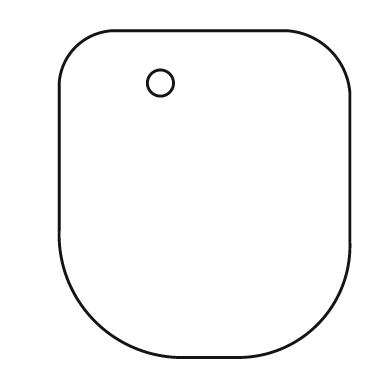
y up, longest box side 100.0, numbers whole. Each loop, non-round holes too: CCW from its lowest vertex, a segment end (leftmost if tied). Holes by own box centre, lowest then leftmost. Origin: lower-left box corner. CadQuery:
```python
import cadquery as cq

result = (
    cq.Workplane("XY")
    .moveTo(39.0, 0.0)
    .lineTo(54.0, 0.0)
    .threePointArc((79.0, 10.0), (89.0, 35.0))
    .lineTo(89.0, 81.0)
    .threePointArc((83.0, 94.0), (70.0, 100.0))
    .lineTo(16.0, 100.0)
    .threePointArc((5.0, 95.0), (0.0, 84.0))
    .lineTo(0.0, 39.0)
    .threePointArc((11.0, 11.0), (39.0, 0.0))
    .close()
    .moveTo(31.0, 84.0)
    .circle(4.0)
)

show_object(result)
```